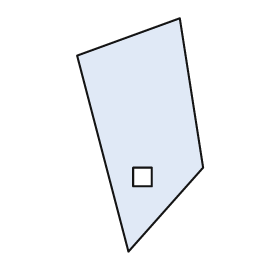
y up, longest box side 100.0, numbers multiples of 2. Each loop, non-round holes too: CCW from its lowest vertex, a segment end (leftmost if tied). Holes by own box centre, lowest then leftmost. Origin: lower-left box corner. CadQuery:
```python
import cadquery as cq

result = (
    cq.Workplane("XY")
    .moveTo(22.0, 0.0)
    .lineTo(54.0, 36.0)
    .lineTo(44.0, 100.0)
    .lineTo(0.0, 84.0)
    .close()
    .moveTo(24.0, 28.0)
    .lineTo(32.0, 28.0)
    .lineTo(32.0, 36.0)
    .lineTo(24.0, 36.0)
    .close()
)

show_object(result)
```